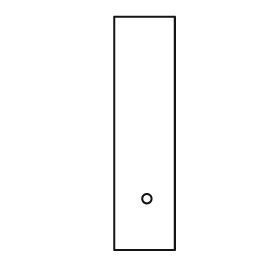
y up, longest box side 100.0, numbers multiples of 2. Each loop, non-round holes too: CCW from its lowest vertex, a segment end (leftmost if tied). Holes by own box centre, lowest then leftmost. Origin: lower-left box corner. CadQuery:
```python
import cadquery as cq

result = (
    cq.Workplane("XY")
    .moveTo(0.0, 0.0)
    .lineTo(26.0, 0.0)
    .lineTo(26.0, 100.0)
    .lineTo(0.0, 100.0)
    .close()
    .moveTo(14.0, 22.0)
    .circle(2.0)
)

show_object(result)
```